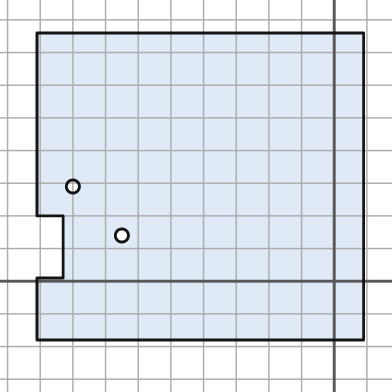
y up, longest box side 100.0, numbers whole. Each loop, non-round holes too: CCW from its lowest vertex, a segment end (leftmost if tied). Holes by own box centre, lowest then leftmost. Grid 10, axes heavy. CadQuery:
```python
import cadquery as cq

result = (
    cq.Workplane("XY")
    .moveTo(-91.0, -18.0)
    .lineTo(9.0, -18.0)
    .lineTo(9.0, 76.0)
    .lineTo(-91.0, 76.0)
    .lineTo(-91.0, 20.0)
    .lineTo(-83.0, 20.0)
    .lineTo(-83.0, 1.0)
    .lineTo(-91.0, 1.0)
    .close()
    .moveTo(-65.0, 14.0)
    .circle(2.0)
    .moveTo(-80.0, 29.0)
    .circle(2.0)
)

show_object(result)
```